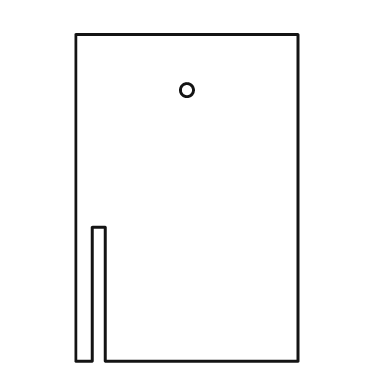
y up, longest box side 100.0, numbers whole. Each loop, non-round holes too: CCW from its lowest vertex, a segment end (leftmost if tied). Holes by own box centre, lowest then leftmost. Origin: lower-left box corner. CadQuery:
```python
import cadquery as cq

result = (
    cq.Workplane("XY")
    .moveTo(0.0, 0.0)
    .lineTo(5.0, 0.0)
    .lineTo(5.0, 41.0)
    .lineTo(9.0, 41.0)
    .lineTo(9.0, 0.0)
    .lineTo(68.0, 0.0)
    .lineTo(68.0, 100.0)
    .lineTo(0.0, 100.0)
    .close()
    .moveTo(34.0, 83.0)
    .circle(2.0)
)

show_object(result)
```